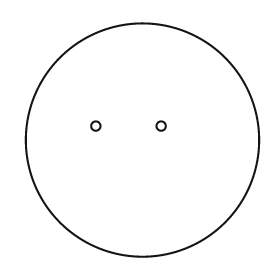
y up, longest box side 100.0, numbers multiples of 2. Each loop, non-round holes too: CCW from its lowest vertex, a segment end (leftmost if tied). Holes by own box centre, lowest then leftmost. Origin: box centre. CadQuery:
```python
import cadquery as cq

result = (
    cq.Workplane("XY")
    .moveTo(0.0, 0.0)
    .circle(50.0)
    .moveTo(-20.0, 6.0)
    .circle(2.0)
    .moveTo(8.0, 6.0)
    .circle(2.0)
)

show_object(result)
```